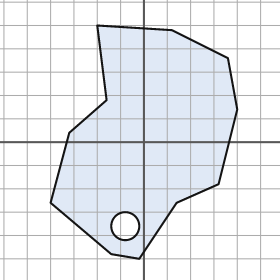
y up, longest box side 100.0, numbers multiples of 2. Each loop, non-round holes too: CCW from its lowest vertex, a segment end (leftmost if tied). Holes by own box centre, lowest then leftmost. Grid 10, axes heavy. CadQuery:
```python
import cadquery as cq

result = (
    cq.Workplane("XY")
    .moveTo(-2.0, -50.0)
    .lineTo(14.0, -26.0)
    .lineTo(32.0, -18.0)
    .lineTo(40.0, 14.0)
    .lineTo(36.0, 36.0)
    .lineTo(12.0, 48.0)
    .lineTo(-20.0, 50.0)
    .lineTo(-16.0, 18.0)
    .lineTo(-32.0, 4.0)
    .lineTo(-40.0, -26.0)
    .lineTo(-14.0, -48.0)
    .close()
    .moveTo(-8.0, -36.0)
    .circle(6.0)
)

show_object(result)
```